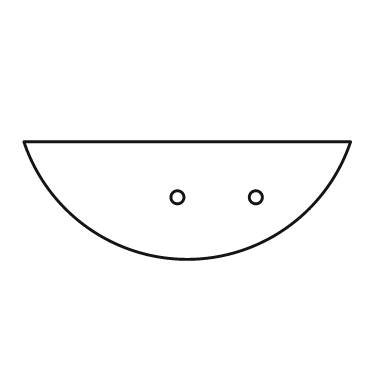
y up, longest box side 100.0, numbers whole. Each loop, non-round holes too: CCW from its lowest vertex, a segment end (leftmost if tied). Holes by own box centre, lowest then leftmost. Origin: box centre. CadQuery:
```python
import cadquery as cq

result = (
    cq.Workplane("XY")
    .moveTo(-50.0, 18.0)
    .threePointArc((0.0, -18.0), (50.0, 18.0))
    .close()
    .moveTo(-3.0, 1.0)
    .circle(2.0)
    .moveTo(21.0, 1.0)
    .circle(2.0)
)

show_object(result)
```